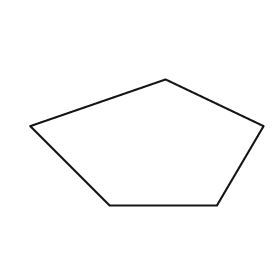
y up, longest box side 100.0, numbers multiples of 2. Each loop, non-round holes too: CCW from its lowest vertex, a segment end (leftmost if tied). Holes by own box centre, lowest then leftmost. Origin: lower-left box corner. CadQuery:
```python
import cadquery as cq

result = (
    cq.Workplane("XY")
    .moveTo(34.0, 0.0)
    .lineTo(80.0, 0.0)
    .lineTo(100.0, 34.0)
    .lineTo(58.0, 54.0)
    .lineTo(0.0, 34.0)
    .close()
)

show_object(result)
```